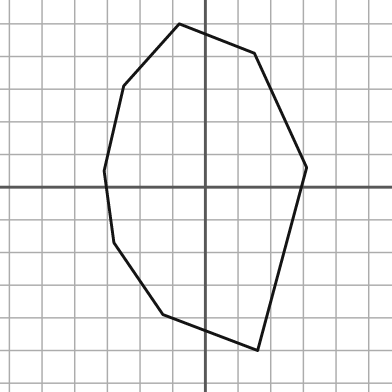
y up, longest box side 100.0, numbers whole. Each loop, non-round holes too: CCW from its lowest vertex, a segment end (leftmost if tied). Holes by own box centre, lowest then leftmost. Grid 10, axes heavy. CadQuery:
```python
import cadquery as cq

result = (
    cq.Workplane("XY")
    .moveTo(16.0, -50.0)
    .lineTo(31.0, 6.0)
    .lineTo(15.0, 41.0)
    .lineTo(-8.0, 50.0)
    .lineTo(-25.0, 31.0)
    .lineTo(-31.0, 5.0)
    .lineTo(-28.0, -17.0)
    .lineTo(-13.0, -39.0)
    .close()
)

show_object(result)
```